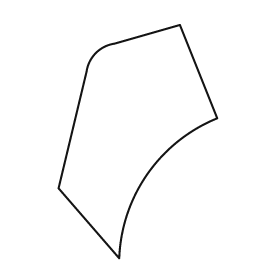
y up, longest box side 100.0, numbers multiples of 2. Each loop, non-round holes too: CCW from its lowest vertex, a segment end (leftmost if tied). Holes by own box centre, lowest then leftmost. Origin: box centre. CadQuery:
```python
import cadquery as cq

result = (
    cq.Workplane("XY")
    .moveTo(-8.0, -50.0)
    .threePointArc((4.0, -14.0), (34.0, 10.0))
    .lineTo(18.0, 50.0)
    .lineTo(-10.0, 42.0)
    .threePointArc((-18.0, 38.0), (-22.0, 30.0))
    .lineTo(-34.0, -20.0)
    .close()
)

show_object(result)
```